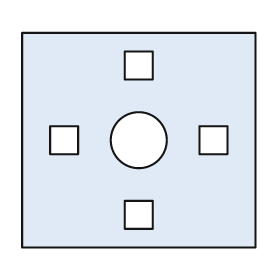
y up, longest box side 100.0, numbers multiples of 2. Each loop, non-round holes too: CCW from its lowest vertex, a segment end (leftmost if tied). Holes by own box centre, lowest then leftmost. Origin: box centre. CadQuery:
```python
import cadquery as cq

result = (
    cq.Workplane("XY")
    .moveTo(-50.0, -46.0)
    .lineTo(50.0, -46.0)
    .lineTo(50.0, 46.0)
    .lineTo(-50.0, 46.0)
    .close()
    .moveTo(-6.0, -38.0)
    .lineTo(6.0, -38.0)
    .lineTo(6.0, -26.0)
    .lineTo(-6.0, -26.0)
    .close()
    .moveTo(-38.0, -6.0)
    .lineTo(-26.0, -6.0)
    .lineTo(-26.0, 6.0)
    .lineTo(-38.0, 6.0)
    .close()
    .moveTo(0.0, 0.0)
    .circle(12.0)
    .moveTo(26.0, -6.0)
    .lineTo(38.0, -6.0)
    .lineTo(38.0, 6.0)
    .lineTo(26.0, 6.0)
    .close()
    .moveTo(-6.0, 26.0)
    .lineTo(6.0, 26.0)
    .lineTo(6.0, 38.0)
    .lineTo(-6.0, 38.0)
    .close()
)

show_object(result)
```